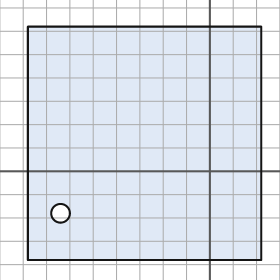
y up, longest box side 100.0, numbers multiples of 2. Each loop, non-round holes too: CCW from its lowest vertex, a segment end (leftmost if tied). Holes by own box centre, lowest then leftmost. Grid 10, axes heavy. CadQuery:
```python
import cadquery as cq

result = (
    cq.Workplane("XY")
    .moveTo(-78.0, -38.0)
    .lineTo(22.0, -38.0)
    .lineTo(22.0, 62.0)
    .lineTo(-78.0, 62.0)
    .close()
    .moveTo(-64.0, -18.0)
    .circle(4.0)
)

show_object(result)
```